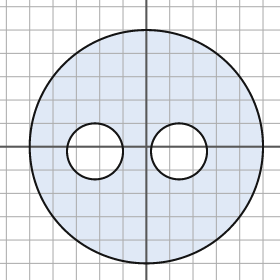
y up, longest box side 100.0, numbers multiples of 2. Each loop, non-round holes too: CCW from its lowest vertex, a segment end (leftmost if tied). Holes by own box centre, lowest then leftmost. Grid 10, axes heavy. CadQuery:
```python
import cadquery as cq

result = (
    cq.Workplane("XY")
    .moveTo(0.0, 0.0)
    .circle(50.0)
    .moveTo(-22.0, -2.0)
    .circle(12.0)
    .moveTo(14.0, -2.0)
    .circle(12.0)
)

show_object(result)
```